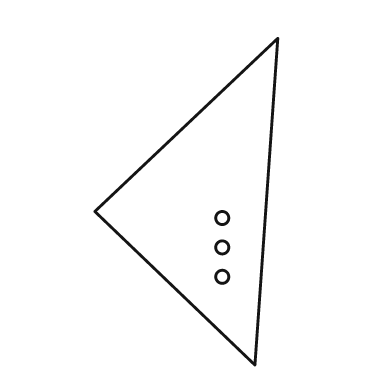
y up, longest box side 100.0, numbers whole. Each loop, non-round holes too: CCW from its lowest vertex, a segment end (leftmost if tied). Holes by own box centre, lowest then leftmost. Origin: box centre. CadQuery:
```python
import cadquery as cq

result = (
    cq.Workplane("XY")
    .moveTo(21.0, -50.0)
    .lineTo(28.0, 50.0)
    .lineTo(-28.0, -3.0)
    .close()
    .moveTo(11.0, -23.0)
    .circle(2.0)
    .moveTo(11.0, -14.0)
    .circle(2.0)
    .moveTo(11.0, -5.0)
    .circle(2.0)
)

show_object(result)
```